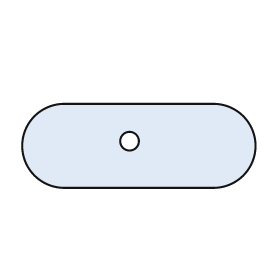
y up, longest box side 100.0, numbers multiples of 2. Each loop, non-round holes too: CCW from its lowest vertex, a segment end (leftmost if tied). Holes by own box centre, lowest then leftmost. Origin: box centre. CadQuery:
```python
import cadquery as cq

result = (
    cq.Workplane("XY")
    .moveTo(-32.0, -18.0)
    .lineTo(32.0, -18.0)
    .threePointArc((50.0, 0.0), (32.0, 18.0))
    .lineTo(-32.0, 18.0)
    .threePointArc((-50.0, 0.0), (-32.0, -18.0))
    .close()
    .moveTo(-4.0, 2.0)
    .circle(4.0)
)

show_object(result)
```